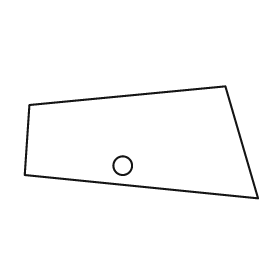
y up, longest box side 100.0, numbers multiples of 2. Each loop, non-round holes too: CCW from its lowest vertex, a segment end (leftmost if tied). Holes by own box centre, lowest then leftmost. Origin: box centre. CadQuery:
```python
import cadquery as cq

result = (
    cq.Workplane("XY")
    .moveTo(50.0, -24.0)
    .lineTo(36.0, 24.0)
    .lineTo(-48.0, 16.0)
    .lineTo(-50.0, -14.0)
    .close()
    .moveTo(-8.0, -10.0)
    .circle(4.0)
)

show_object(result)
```